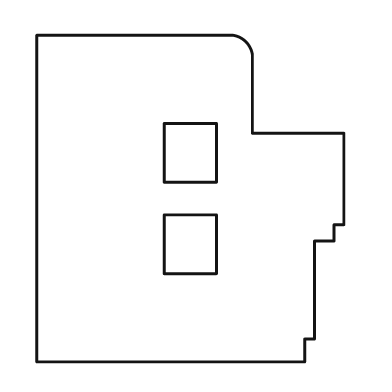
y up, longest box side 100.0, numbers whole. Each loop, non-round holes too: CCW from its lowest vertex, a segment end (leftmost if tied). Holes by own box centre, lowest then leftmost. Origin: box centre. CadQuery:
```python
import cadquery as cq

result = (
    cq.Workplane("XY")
    .moveTo(-47.0, -50.0)
    .lineTo(35.0, -50.0)
    .lineTo(35.0, -43.0)
    .lineTo(38.0, -43.0)
    .lineTo(38.0, -13.0)
    .lineTo(44.0, -13.0)
    .lineTo(44.0, -8.0)
    .lineTo(47.0, -8.0)
    .lineTo(47.0, 20.0)
    .lineTo(19.0, 20.0)
    .lineTo(19.0, 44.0)
    .threePointArc((17.0, 48.0), (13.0, 50.0))
    .lineTo(-47.0, 50.0)
    .close()
    .moveTo(-8.0, -23.0)
    .lineTo(8.0, -23.0)
    .lineTo(8.0, -5.0)
    .lineTo(-8.0, -5.0)
    .close()
    .moveTo(-8.0, 5.0)
    .lineTo(8.0, 5.0)
    .lineTo(8.0, 23.0)
    .lineTo(-8.0, 23.0)
    .close()
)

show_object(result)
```